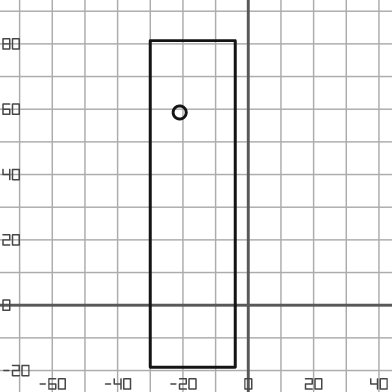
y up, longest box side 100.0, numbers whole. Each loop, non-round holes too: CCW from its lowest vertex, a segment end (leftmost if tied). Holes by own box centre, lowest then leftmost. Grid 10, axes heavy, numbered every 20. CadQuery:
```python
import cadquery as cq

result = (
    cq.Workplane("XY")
    .moveTo(-30.0, -19.0)
    .lineTo(-4.0, -19.0)
    .lineTo(-4.0, 81.0)
    .lineTo(-30.0, 81.0)
    .close()
    .moveTo(-21.0, 59.0)
    .circle(2.0)
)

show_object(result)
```